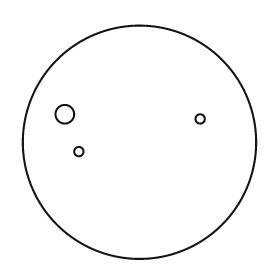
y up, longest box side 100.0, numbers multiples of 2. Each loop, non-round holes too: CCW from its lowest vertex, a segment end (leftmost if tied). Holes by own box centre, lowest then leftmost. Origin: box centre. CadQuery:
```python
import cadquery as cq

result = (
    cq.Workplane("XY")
    .moveTo(0.0, 0.0)
    .circle(50.0)
    .moveTo(-26.0, -4.0)
    .circle(2.0)
    .moveTo(26.0, 10.0)
    .circle(2.0)
    .moveTo(-32.0, 12.0)
    .circle(4.0)
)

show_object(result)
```